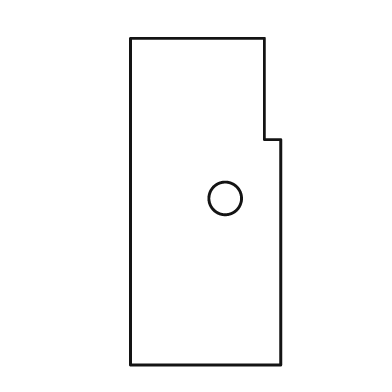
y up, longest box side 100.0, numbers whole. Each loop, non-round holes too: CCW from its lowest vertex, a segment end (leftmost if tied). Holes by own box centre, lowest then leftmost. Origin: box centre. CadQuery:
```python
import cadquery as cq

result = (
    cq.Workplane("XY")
    .moveTo(-23.0, -50.0)
    .lineTo(23.0, -50.0)
    .lineTo(23.0, 19.0)
    .lineTo(18.0, 19.0)
    .lineTo(18.0, 50.0)
    .lineTo(-23.0, 50.0)
    .close()
    .moveTo(6.0, 1.0)
    .circle(5.0)
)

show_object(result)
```